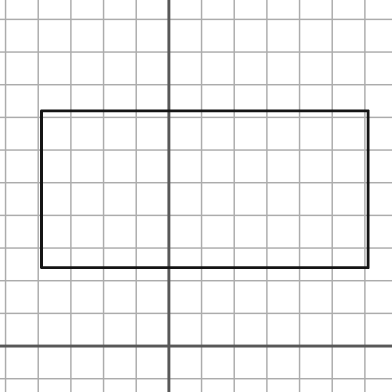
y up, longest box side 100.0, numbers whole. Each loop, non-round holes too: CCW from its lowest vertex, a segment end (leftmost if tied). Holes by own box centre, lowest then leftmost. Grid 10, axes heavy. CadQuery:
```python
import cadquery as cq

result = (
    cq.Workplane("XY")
    .moveTo(-39.0, 24.0)
    .lineTo(61.0, 24.0)
    .lineTo(61.0, 72.0)
    .lineTo(-39.0, 72.0)
    .close()
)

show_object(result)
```